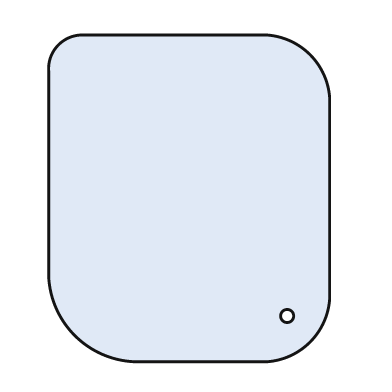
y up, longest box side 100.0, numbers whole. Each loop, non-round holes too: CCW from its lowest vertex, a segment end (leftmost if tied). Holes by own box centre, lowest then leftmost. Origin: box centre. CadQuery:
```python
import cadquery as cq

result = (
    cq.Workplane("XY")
    .moveTo(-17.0, -50.0)
    .lineTo(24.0, -50.0)
    .threePointArc((37.0, -44.0), (43.0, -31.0))
    .lineTo(43.0, 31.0)
    .threePointArc((37.0, 44.0), (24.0, 50.0))
    .lineTo(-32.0, 50.0)
    .threePointArc((-40.0, 47.0), (-43.0, 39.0))
    .lineTo(-43.0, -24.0)
    .threePointArc((-35.0, -42.0), (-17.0, -50.0))
    .close()
    .moveTo(30.0, -36.0)
    .circle(2.0)
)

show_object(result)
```